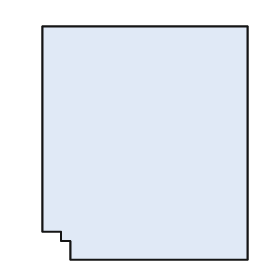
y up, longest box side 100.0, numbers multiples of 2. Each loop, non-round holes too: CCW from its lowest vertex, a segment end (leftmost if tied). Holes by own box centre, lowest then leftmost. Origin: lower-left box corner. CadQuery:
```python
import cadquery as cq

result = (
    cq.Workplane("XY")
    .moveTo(12.0, 0.0)
    .lineTo(88.0, 0.0)
    .lineTo(88.0, 100.0)
    .lineTo(0.0, 100.0)
    .lineTo(0.0, 12.0)
    .lineTo(8.0, 12.0)
    .lineTo(8.0, 8.0)
    .lineTo(12.0, 8.0)
    .close()
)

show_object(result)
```